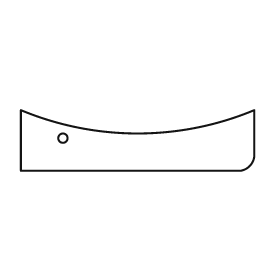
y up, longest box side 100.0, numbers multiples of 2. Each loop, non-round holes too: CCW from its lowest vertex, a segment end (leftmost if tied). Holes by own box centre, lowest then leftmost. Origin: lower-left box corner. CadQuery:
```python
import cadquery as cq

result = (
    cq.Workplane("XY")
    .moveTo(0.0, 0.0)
    .lineTo(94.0, 0.0)
    .threePointArc((98.0, 2.0), (100.0, 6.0))
    .lineTo(100.0, 26.0)
    .threePointArc((50.0, 16.0), (0.0, 26.0))
    .close()
    .moveTo(18.0, 14.0)
    .circle(2.0)
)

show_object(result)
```